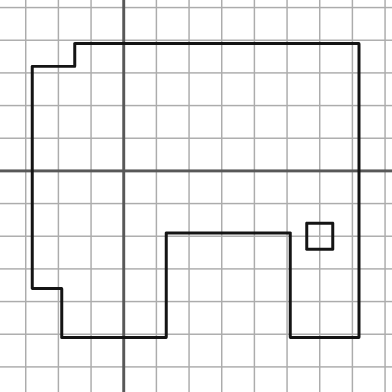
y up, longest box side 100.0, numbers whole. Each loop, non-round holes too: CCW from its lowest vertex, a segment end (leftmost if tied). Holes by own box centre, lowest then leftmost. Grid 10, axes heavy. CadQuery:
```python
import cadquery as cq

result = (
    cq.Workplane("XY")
    .moveTo(-19.0, -51.0)
    .lineTo(13.0, -51.0)
    .lineTo(13.0, -19.0)
    .lineTo(51.0, -19.0)
    .lineTo(51.0, -51.0)
    .lineTo(72.0, -51.0)
    .lineTo(72.0, 39.0)
    .lineTo(-15.0, 39.0)
    .lineTo(-15.0, 32.0)
    .lineTo(-28.0, 32.0)
    .lineTo(-28.0, -36.0)
    .lineTo(-19.0, -36.0)
    .close()
    .moveTo(56.0, -24.0)
    .lineTo(64.0, -24.0)
    .lineTo(64.0, -16.0)
    .lineTo(56.0, -16.0)
    .close()
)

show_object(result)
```